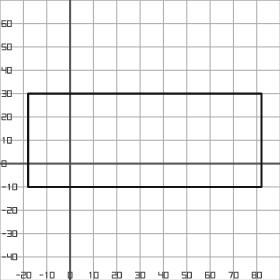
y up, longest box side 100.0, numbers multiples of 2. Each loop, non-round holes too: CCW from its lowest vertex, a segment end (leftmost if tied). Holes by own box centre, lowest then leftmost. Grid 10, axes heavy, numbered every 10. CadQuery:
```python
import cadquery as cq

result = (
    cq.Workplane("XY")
    .moveTo(-18.0, -10.0)
    .lineTo(82.0, -10.0)
    .lineTo(82.0, 30.0)
    .lineTo(-18.0, 30.0)
    .close()
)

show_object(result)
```